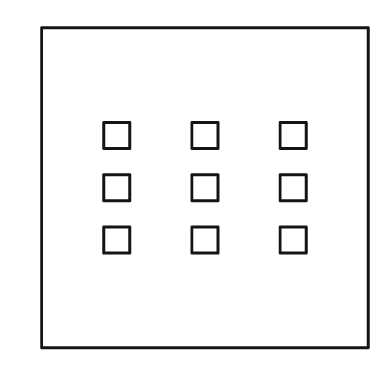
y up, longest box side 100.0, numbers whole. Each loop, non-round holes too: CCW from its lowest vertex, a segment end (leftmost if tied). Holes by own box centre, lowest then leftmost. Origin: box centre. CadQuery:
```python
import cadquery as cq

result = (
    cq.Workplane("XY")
    .moveTo(-50.0, -49.0)
    .lineTo(50.0, -49.0)
    .lineTo(50.0, 49.0)
    .lineTo(-50.0, 49.0)
    .close()
    .moveTo(-31.0, -20.0)
    .lineTo(-23.0, -20.0)
    .lineTo(-23.0, -12.0)
    .lineTo(-31.0, -12.0)
    .close()
    .moveTo(-4.0, -20.0)
    .lineTo(4.0, -20.0)
    .lineTo(4.0, -12.0)
    .lineTo(-4.0, -12.0)
    .close()
    .moveTo(23.0, -20.0)
    .lineTo(31.0, -20.0)
    .lineTo(31.0, -12.0)
    .lineTo(23.0, -12.0)
    .close()
    .moveTo(-31.0, -4.0)
    .lineTo(-23.0, -4.0)
    .lineTo(-23.0, 4.0)
    .lineTo(-31.0, 4.0)
    .close()
    .moveTo(-4.0, -4.0)
    .lineTo(4.0, -4.0)
    .lineTo(4.0, 4.0)
    .lineTo(-4.0, 4.0)
    .close()
    .moveTo(23.0, -4.0)
    .lineTo(31.0, -4.0)
    .lineTo(31.0, 4.0)
    .lineTo(23.0, 4.0)
    .close()
    .moveTo(-31.0, 12.0)
    .lineTo(-23.0, 12.0)
    .lineTo(-23.0, 20.0)
    .lineTo(-31.0, 20.0)
    .close()
    .moveTo(-4.0, 12.0)
    .lineTo(4.0, 12.0)
    .lineTo(4.0, 20.0)
    .lineTo(-4.0, 20.0)
    .close()
    .moveTo(23.0, 12.0)
    .lineTo(31.0, 12.0)
    .lineTo(31.0, 20.0)
    .lineTo(23.0, 20.0)
    .close()
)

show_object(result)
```